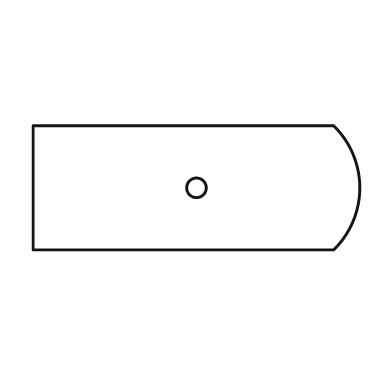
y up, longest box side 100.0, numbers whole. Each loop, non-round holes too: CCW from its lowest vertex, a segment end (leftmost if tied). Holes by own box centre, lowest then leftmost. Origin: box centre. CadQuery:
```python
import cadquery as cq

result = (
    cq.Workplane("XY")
    .moveTo(-50.0, -19.0)
    .lineTo(42.0, -19.0)
    .threePointArc((50.0, 0.0), (42.0, 19.0))
    .lineTo(-50.0, 19.0)
    .close()
    .moveTo(0.0, 0.0)
    .circle(3.0)
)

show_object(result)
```